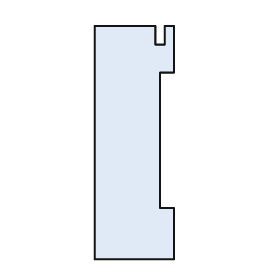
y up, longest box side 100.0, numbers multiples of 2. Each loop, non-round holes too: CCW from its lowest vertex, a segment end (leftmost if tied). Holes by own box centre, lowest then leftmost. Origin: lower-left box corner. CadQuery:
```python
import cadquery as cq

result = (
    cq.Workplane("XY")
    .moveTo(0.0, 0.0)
    .lineTo(34.0, 0.0)
    .lineTo(34.0, 22.0)
    .lineTo(28.0, 22.0)
    .lineTo(28.0, 80.0)
    .lineTo(34.0, 80.0)
    .lineTo(34.0, 100.0)
    .lineTo(30.0, 100.0)
    .lineTo(30.0, 92.0)
    .lineTo(26.0, 92.0)
    .lineTo(26.0, 100.0)
    .lineTo(0.0, 100.0)
    .close()
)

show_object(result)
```